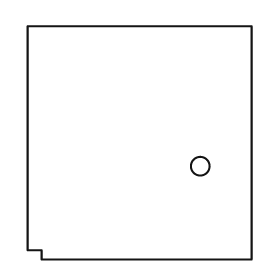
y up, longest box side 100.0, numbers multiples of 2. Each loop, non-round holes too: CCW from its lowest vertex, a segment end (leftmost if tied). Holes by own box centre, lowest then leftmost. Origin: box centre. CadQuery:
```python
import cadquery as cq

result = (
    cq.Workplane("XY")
    .moveTo(-42.0, -50.0)
    .lineTo(48.0, -50.0)
    .lineTo(48.0, 50.0)
    .lineTo(-48.0, 50.0)
    .lineTo(-48.0, -46.0)
    .lineTo(-42.0, -46.0)
    .close()
    .moveTo(26.0, -10.0)
    .circle(4.0)
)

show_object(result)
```